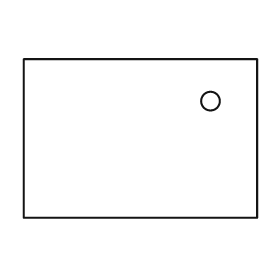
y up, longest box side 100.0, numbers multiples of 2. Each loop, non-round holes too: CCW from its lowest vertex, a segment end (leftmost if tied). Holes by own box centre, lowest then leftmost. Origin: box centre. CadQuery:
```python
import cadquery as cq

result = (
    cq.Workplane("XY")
    .moveTo(-50.0, -34.0)
    .lineTo(50.0, -34.0)
    .lineTo(50.0, 34.0)
    .lineTo(-50.0, 34.0)
    .close()
    .moveTo(30.0, 16.0)
    .circle(4.0)
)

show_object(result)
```